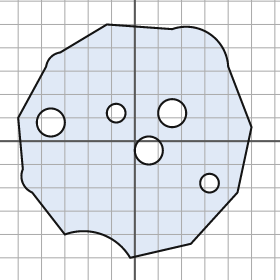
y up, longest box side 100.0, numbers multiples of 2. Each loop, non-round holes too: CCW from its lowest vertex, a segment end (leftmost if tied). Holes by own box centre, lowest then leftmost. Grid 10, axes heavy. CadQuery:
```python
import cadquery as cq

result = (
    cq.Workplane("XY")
    .moveTo(-2.0, -50.0)
    .lineTo(24.0, -44.0)
    .lineTo(44.0, -22.0)
    .lineTo(50.0, 6.0)
    .lineTo(40.0, 32.0)
    .threePointArc((32.0, 46.0), (16.0, 48.0))
    .lineTo(-12.0, 50.0)
    .lineTo(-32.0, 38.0)
    .threePointArc((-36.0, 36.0), (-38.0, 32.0))
    .lineTo(-50.0, 10.0)
    .lineTo(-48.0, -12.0)
    .threePointArc((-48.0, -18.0), (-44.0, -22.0))
    .lineTo(-30.0, -40.0)
    .threePointArc((-14.0, -40.0), (-2.0, -50.0))
    .close()
    .moveTo(32.0, -18.0)
    .circle(4.0)
    .moveTo(6.0, -4.0)
    .circle(6.0)
    .moveTo(-36.0, 8.0)
    .circle(6.0)
    .moveTo(-8.0, 12.0)
    .circle(4.0)
    .moveTo(16.0, 12.0)
    .circle(6.0)
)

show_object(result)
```